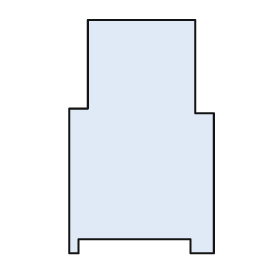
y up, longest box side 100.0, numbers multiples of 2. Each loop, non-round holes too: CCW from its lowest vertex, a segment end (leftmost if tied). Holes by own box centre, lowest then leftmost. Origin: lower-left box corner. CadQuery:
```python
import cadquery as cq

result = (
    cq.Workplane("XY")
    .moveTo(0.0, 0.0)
    .lineTo(4.0, 0.0)
    .lineTo(4.0, 6.0)
    .lineTo(52.0, 6.0)
    .lineTo(52.0, 0.0)
    .lineTo(62.0, 0.0)
    .lineTo(62.0, 60.0)
    .lineTo(54.0, 60.0)
    .lineTo(54.0, 100.0)
    .lineTo(8.0, 100.0)
    .lineTo(8.0, 62.0)
    .lineTo(0.0, 62.0)
    .close()
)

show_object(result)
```